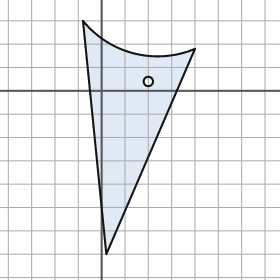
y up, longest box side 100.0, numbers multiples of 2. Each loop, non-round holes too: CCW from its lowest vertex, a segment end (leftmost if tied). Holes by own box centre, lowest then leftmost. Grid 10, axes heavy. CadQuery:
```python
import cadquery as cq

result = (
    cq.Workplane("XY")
    .moveTo(2.0, -70.0)
    .lineTo(40.0, 18.0)
    .threePointArc((14.0, 16.0), (-8.0, 30.0))
    .close()
    .moveTo(20.0, 4.0)
    .circle(2.0)
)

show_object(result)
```